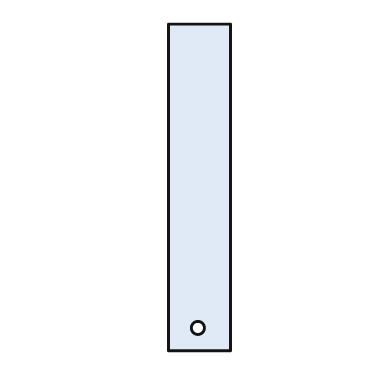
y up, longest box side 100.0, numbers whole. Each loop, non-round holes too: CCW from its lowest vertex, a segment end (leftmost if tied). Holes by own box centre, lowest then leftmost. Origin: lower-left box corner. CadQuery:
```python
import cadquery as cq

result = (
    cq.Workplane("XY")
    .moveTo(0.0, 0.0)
    .lineTo(19.0, 0.0)
    .lineTo(19.0, 100.0)
    .lineTo(0.0, 100.0)
    .close()
    .moveTo(9.0, 7.0)
    .circle(2.0)
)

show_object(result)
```